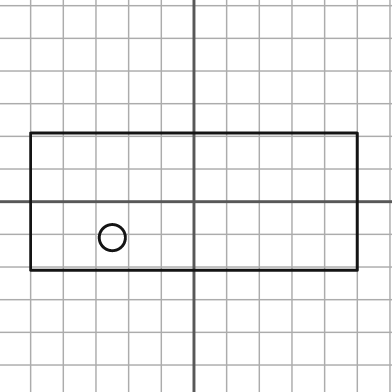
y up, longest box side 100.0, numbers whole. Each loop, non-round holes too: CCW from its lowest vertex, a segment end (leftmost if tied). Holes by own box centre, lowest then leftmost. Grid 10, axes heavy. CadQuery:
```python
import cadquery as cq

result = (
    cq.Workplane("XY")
    .moveTo(-50.0, -21.0)
    .lineTo(50.0, -21.0)
    .lineTo(50.0, 21.0)
    .lineTo(-50.0, 21.0)
    .close()
    .moveTo(-25.0, -11.0)
    .circle(4.0)
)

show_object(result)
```